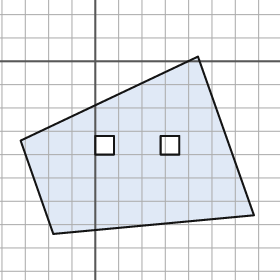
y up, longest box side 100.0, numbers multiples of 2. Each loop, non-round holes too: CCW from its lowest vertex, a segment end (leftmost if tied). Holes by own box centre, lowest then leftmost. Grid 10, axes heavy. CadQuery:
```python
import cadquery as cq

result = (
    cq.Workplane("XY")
    .moveTo(-18.0, -74.0)
    .lineTo(68.0, -66.0)
    .lineTo(44.0, 2.0)
    .lineTo(-32.0, -34.0)
    .close()
    .moveTo(0.0, -40.0)
    .lineTo(8.0, -40.0)
    .lineTo(8.0, -32.0)
    .lineTo(0.0, -32.0)
    .close()
    .moveTo(28.0, -40.0)
    .lineTo(36.0, -40.0)
    .lineTo(36.0, -32.0)
    .lineTo(28.0, -32.0)
    .close()
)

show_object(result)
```